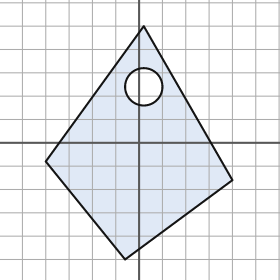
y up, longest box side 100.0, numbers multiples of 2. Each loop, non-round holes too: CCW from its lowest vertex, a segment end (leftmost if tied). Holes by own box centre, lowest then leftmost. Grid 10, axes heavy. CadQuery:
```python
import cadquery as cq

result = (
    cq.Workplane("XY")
    .moveTo(-6.0, -50.0)
    .lineTo(40.0, -16.0)
    .lineTo(2.0, 50.0)
    .lineTo(-40.0, -8.0)
    .close()
    .moveTo(2.0, 24.0)
    .circle(8.0)
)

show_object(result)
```